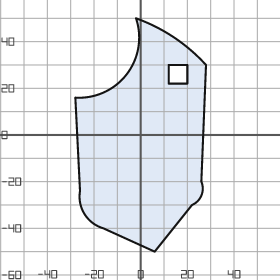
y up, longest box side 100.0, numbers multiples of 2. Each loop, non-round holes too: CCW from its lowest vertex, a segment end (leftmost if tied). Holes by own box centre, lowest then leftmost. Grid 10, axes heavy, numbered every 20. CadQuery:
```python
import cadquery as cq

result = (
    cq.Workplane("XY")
    .moveTo(6.0, -50.0)
    .lineTo(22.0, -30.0)
    .threePointArc((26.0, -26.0), (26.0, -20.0))
    .lineTo(28.0, 30.0)
    .threePointArc((14.0, 42.0), (-2.0, 50.0))
    .threePointArc((-6.0, 26.0), (-28.0, 16.0))
    .lineTo(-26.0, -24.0)
    .threePointArc((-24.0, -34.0), (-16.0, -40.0))
    .close()
    .moveTo(12.0, 22.0)
    .lineTo(20.0, 22.0)
    .lineTo(20.0, 30.0)
    .lineTo(12.0, 30.0)
    .close()
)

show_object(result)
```